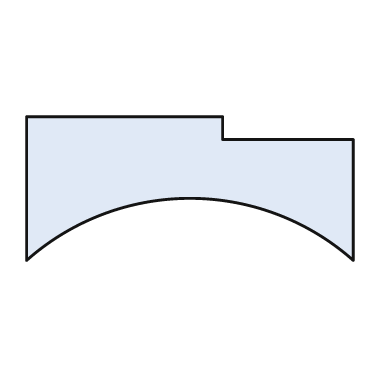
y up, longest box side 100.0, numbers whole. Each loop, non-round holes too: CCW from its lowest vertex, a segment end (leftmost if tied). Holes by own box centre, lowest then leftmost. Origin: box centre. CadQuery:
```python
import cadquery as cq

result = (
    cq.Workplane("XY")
    .moveTo(-50.0, -22.0)
    .threePointArc((0.0, -3.0), (50.0, -22.0))
    .lineTo(50.0, 15.0)
    .lineTo(10.0, 15.0)
    .lineTo(10.0, 22.0)
    .lineTo(-50.0, 22.0)
    .close()
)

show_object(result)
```